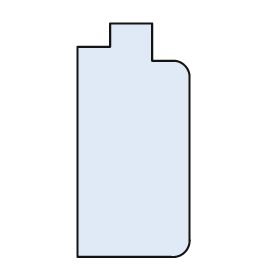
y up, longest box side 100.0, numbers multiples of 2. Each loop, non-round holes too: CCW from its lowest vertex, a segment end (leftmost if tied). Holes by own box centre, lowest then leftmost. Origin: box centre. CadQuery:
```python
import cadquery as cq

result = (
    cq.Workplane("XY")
    .moveTo(-24.0, -50.0)
    .lineTo(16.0, -50.0)
    .threePointArc((22.0, -48.0), (24.0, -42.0))
    .lineTo(24.0, 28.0)
    .threePointArc((22.0, 32.0), (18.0, 34.0))
    .lineTo(8.0, 34.0)
    .lineTo(8.0, 50.0)
    .lineTo(-10.0, 50.0)
    .lineTo(-10.0, 40.0)
    .lineTo(-24.0, 40.0)
    .close()
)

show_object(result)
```